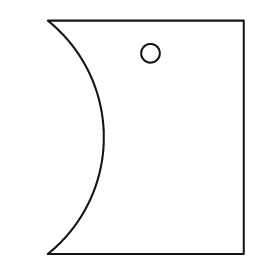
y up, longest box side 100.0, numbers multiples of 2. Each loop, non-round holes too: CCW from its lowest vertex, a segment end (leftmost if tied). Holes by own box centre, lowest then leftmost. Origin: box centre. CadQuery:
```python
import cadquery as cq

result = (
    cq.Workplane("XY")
    .moveTo(-42.0, -50.0)
    .lineTo(42.0, -50.0)
    .lineTo(42.0, 50.0)
    .lineTo(-42.0, 50.0)
    .threePointArc((-18.0, 0.0), (-42.0, -50.0))
    .close()
    .moveTo(2.0, 36.0)
    .circle(4.0)
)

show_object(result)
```